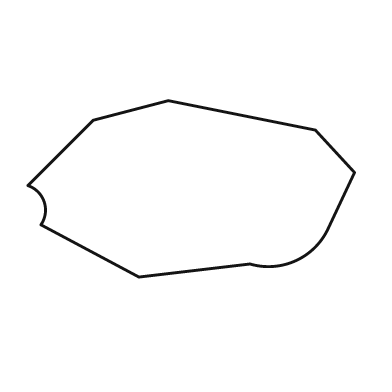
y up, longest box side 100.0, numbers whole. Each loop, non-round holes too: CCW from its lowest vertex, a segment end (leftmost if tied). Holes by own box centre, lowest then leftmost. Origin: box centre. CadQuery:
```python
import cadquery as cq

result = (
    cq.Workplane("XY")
    .moveTo(-16.0, -27.0)
    .lineTo(18.0, -23.0)
    .threePointArc((32.0, -22.0), (42.0, -12.0))
    .lineTo(50.0, 5.0)
    .lineTo(38.0, 18.0)
    .lineTo(-7.0, 27.0)
    .lineTo(-30.0, 21.0)
    .lineTo(-50.0, 1.0)
    .threePointArc((-45.0, -4.0), (-46.0, -11.0))
    .close()
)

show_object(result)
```